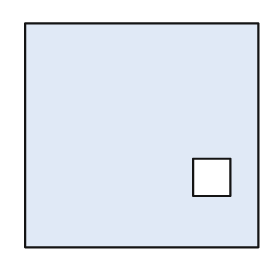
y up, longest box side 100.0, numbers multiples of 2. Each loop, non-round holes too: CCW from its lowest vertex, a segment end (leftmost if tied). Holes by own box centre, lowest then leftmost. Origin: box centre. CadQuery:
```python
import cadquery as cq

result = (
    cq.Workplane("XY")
    .moveTo(-50.0, -48.0)
    .lineTo(50.0, -48.0)
    .lineTo(50.0, 48.0)
    .lineTo(-50.0, 48.0)
    .close()
    .moveTo(22.0, -26.0)
    .lineTo(38.0, -26.0)
    .lineTo(38.0, -10.0)
    .lineTo(22.0, -10.0)
    .close()
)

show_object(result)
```